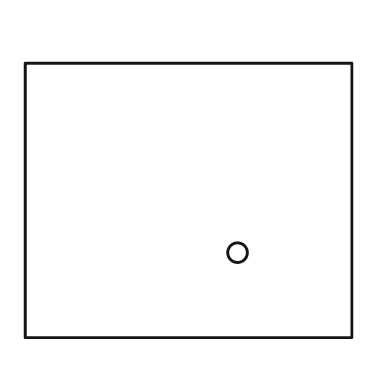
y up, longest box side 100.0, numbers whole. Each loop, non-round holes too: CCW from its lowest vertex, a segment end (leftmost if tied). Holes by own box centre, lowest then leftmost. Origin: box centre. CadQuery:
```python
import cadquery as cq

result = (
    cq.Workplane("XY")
    .moveTo(-50.0, -42.0)
    .lineTo(50.0, -42.0)
    .lineTo(50.0, 42.0)
    .lineTo(-50.0, 42.0)
    .close()
    .moveTo(15.0, -16.0)
    .circle(3.0)
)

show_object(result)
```